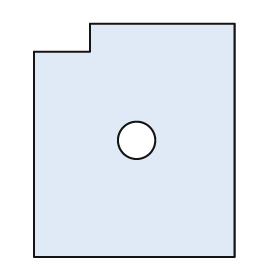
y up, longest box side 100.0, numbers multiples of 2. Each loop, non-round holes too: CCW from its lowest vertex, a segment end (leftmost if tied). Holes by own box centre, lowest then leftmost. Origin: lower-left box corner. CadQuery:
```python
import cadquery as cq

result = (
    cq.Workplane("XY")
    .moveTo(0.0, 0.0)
    .lineTo(86.0, 0.0)
    .lineTo(86.0, 100.0)
    .lineTo(24.0, 100.0)
    .lineTo(24.0, 88.0)
    .lineTo(0.0, 88.0)
    .close()
    .moveTo(44.0, 50.0)
    .circle(8.0)
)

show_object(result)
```